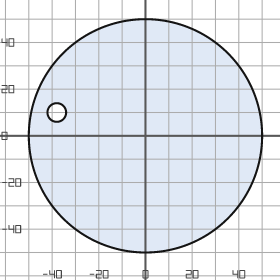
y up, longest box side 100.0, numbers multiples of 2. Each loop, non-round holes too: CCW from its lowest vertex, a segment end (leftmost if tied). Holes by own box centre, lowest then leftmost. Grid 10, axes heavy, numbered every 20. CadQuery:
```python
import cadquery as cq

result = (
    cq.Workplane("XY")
    .moveTo(0.0, 0.0)
    .circle(50.0)
    .moveTo(-38.0, 10.0)
    .circle(4.0)
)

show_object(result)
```